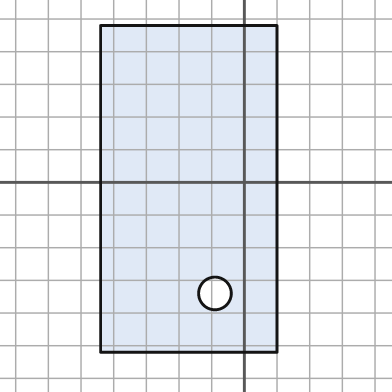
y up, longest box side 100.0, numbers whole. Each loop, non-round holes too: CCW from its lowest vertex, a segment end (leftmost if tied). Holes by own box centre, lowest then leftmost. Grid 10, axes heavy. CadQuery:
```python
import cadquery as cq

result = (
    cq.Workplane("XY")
    .moveTo(-44.0, -52.0)
    .lineTo(10.0, -52.0)
    .lineTo(10.0, 48.0)
    .lineTo(-44.0, 48.0)
    .close()
    .moveTo(-9.0, -34.0)
    .circle(5.0)
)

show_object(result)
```